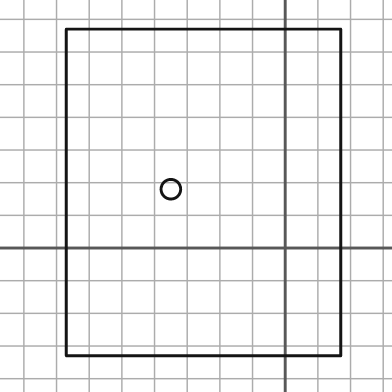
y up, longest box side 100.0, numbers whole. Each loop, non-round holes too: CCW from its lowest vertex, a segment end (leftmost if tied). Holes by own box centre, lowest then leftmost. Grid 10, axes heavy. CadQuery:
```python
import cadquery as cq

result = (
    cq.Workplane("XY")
    .moveTo(-67.0, -33.0)
    .lineTo(17.0, -33.0)
    .lineTo(17.0, 67.0)
    .lineTo(-67.0, 67.0)
    .close()
    .moveTo(-35.0, 18.0)
    .circle(3.0)
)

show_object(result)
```